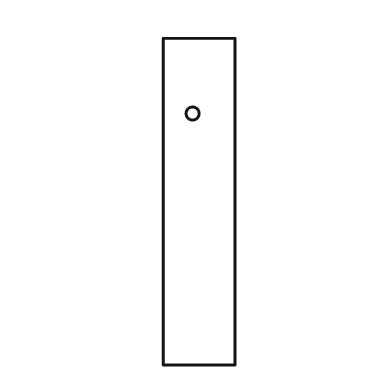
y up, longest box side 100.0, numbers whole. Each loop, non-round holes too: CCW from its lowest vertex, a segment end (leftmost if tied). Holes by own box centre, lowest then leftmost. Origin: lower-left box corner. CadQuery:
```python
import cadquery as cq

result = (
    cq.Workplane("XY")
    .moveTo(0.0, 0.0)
    .lineTo(22.0, 0.0)
    .lineTo(22.0, 100.0)
    .lineTo(0.0, 100.0)
    .close()
    .moveTo(9.0, 77.0)
    .circle(2.0)
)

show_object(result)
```